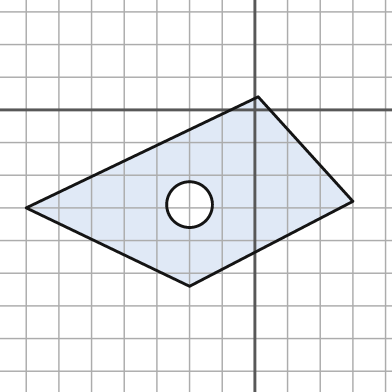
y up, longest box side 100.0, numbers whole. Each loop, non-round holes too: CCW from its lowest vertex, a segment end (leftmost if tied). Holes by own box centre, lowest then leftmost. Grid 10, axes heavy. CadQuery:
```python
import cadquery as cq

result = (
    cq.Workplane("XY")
    .moveTo(-20.0, -54.0)
    .lineTo(30.0, -28.0)
    .lineTo(1.0, 4.0)
    .lineTo(-70.0, -30.0)
    .close()
    .moveTo(-20.0, -29.0)
    .circle(7.0)
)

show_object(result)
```